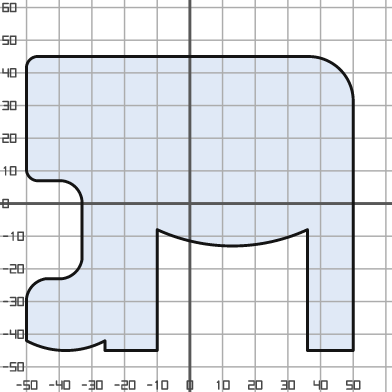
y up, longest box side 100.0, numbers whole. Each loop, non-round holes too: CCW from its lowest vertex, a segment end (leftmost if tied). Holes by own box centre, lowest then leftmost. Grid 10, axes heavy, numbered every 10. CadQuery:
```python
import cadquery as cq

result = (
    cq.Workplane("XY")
    .moveTo(-26.0, -45.0)
    .lineTo(-10.0, -45.0)
    .lineTo(-10.0, -8.0)
    .threePointArc((13.0, -13.0), (36.0, -8.0))
    .lineTo(36.0, -45.0)
    .lineTo(50.0, -45.0)
    .lineTo(50.0, 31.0)
    .threePointArc((46.0, 41.0), (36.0, 45.0))
    .lineTo(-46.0, 45.0)
    .threePointArc((-49.0, 44.0), (-50.0, 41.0))
    .lineTo(-50.0, 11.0)
    .threePointArc((-49.0, 8.0), (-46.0, 7.0))
    .lineTo(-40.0, 7.0)
    .threePointArc((-35.0, 5.0), (-33.0, 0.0))
    .lineTo(-33.0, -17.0)
    .threePointArc((-35.0, -21.0), (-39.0, -23.0))
    .lineTo(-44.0, -23.0)
    .threePointArc((-48.0, -25.0), (-50.0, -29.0))
    .lineTo(-50.0, -42.0)
    .threePointArc((-38.0, -45.0), (-26.0, -42.0))
    .close()
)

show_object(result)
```